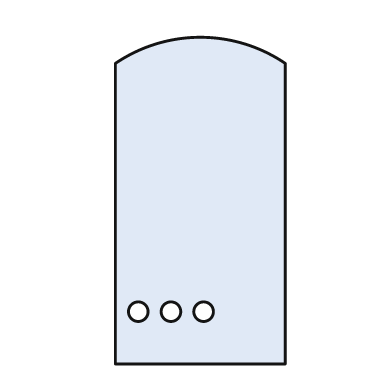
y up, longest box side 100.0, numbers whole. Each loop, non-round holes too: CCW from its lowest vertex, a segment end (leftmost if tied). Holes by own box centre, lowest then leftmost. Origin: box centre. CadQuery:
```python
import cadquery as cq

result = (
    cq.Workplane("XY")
    .moveTo(-26.0, -50.0)
    .lineTo(26.0, -50.0)
    .lineTo(26.0, 42.0)
    .threePointArc((0.0, 50.0), (-26.0, 42.0))
    .close()
    .moveTo(-19.0, -34.0)
    .circle(3.0)
    .moveTo(-9.0, -34.0)
    .circle(3.0)
    .moveTo(1.0, -34.0)
    .circle(3.0)
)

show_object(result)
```